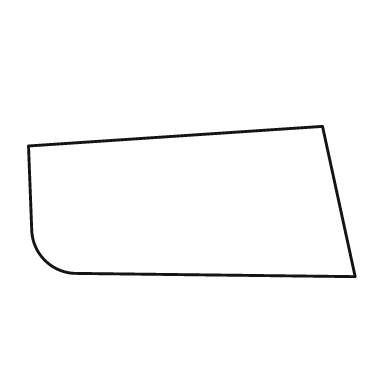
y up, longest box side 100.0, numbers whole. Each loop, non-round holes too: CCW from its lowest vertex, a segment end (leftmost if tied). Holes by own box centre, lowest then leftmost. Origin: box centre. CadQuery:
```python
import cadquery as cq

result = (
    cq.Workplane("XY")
    .moveTo(50.0, -23.0)
    .lineTo(40.0, 23.0)
    .lineTo(-50.0, 17.0)
    .lineTo(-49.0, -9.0)
    .threePointArc((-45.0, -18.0), (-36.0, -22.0))
    .close()
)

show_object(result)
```